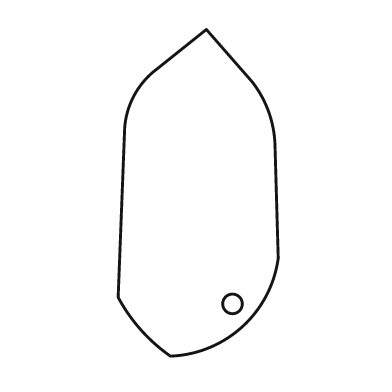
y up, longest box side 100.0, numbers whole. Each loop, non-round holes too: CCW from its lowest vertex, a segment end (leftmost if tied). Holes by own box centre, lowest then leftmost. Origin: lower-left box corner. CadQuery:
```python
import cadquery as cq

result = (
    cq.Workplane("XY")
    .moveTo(16.0, 0.0)
    .threePointArc((38.0, 9.0), (49.0, 30.0))
    .lineTo(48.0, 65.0)
    .threePointArc((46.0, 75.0), (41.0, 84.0))
    .lineTo(27.0, 100.0)
    .lineTo(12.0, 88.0)
    .threePointArc((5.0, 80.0), (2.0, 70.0))
    .lineTo(0.0, 18.0)
    .threePointArc((7.0, 8.0), (16.0, 0.0))
    .close()
    .moveTo(35.0, 16.0)
    .circle(3.0)
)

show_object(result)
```